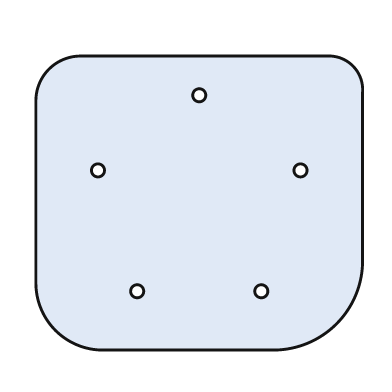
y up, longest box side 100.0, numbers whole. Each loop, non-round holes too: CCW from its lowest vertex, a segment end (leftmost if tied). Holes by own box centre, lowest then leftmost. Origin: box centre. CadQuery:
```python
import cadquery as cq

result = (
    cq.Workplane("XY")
    .moveTo(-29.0, -45.0)
    .lineTo(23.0, -45.0)
    .threePointArc((42.0, -37.0), (50.0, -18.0))
    .lineTo(50.0, 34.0)
    .threePointArc((47.0, 42.0), (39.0, 45.0))
    .lineTo(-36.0, 45.0)
    .threePointArc((-46.0, 41.0), (-50.0, 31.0))
    .lineTo(-50.0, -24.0)
    .threePointArc((-44.0, -39.0), (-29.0, -45.0))
    .close()
    .moveTo(-19.0, -27.0)
    .circle(2.0)
    .moveTo(19.0, -27.0)
    .circle(2.0)
    .moveTo(-31.0, 10.0)
    .circle(2.0)
    .moveTo(31.0, 10.0)
    .circle(2.0)
    .moveTo(0.0, 33.0)
    .circle(2.0)
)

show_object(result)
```